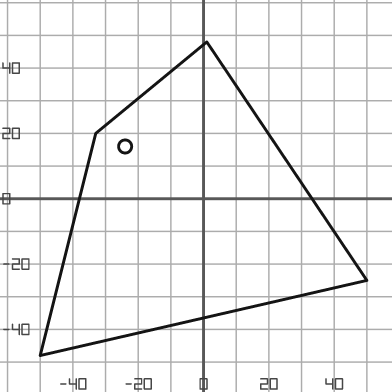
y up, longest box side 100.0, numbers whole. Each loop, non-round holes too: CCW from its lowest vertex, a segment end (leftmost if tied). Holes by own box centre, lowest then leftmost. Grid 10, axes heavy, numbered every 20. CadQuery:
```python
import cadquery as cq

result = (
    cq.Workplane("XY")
    .moveTo(-50.0, -48.0)
    .lineTo(50.0, -25.0)
    .lineTo(1.0, 48.0)
    .lineTo(-33.0, 20.0)
    .close()
    .moveTo(-24.0, 16.0)
    .circle(2.0)
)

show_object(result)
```